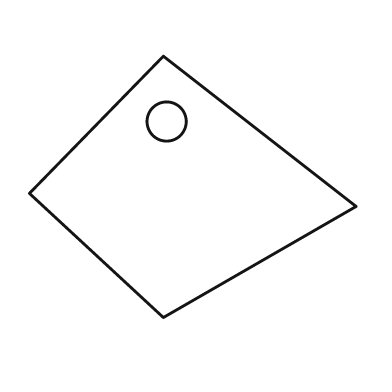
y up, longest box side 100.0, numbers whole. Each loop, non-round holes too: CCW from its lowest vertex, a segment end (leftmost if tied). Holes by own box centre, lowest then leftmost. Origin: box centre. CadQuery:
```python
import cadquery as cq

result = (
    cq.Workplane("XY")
    .moveTo(-9.0, -40.0)
    .lineTo(50.0, -6.0)
    .lineTo(-9.0, 40.0)
    .lineTo(-50.0, -2.0)
    .close()
    .moveTo(-8.0, 20.0)
    .circle(6.0)
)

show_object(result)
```